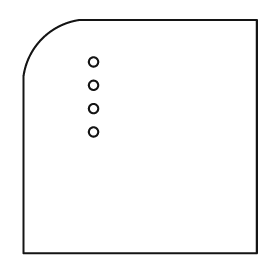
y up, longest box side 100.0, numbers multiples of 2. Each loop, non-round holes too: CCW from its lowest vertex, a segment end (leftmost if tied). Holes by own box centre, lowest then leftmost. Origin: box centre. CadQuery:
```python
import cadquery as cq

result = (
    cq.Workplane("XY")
    .moveTo(-50.0, -50.0)
    .lineTo(50.0, -50.0)
    .lineTo(50.0, 50.0)
    .lineTo(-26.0, 50.0)
    .threePointArc((-42.0, 42.0), (-50.0, 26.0))
    .close()
    .moveTo(-20.0, 2.0)
    .circle(2.0)
    .moveTo(-20.0, 12.0)
    .circle(2.0)
    .moveTo(-20.0, 22.0)
    .circle(2.0)
    .moveTo(-20.0, 32.0)
    .circle(2.0)
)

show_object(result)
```